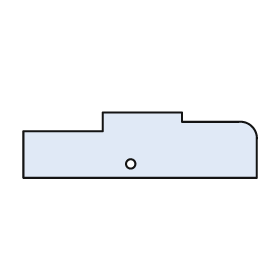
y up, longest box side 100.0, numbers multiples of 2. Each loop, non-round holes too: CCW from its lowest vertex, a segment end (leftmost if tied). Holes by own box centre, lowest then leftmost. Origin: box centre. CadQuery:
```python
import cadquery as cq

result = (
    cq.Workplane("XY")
    .moveTo(-50.0, -14.0)
    .lineTo(50.0, -14.0)
    .lineTo(50.0, 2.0)
    .threePointArc((48.0, 8.0), (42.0, 10.0))
    .lineTo(18.0, 10.0)
    .lineTo(18.0, 14.0)
    .lineTo(-16.0, 14.0)
    .lineTo(-16.0, 6.0)
    .lineTo(-50.0, 6.0)
    .close()
    .moveTo(-4.0, -8.0)
    .circle(2.0)
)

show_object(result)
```